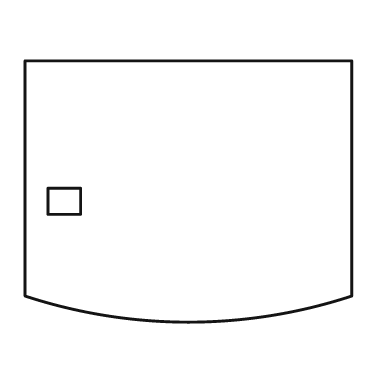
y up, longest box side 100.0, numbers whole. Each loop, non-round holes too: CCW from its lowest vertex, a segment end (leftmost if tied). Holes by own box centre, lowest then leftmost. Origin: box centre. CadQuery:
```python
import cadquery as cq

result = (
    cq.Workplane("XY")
    .moveTo(-50.0, -32.0)
    .threePointArc((0.0, -40.0), (50.0, -32.0))
    .lineTo(50.0, 40.0)
    .lineTo(-50.0, 40.0)
    .close()
    .moveTo(-43.0, -7.0)
    .lineTo(-33.0, -7.0)
    .lineTo(-33.0, 1.0)
    .lineTo(-43.0, 1.0)
    .close()
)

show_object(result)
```